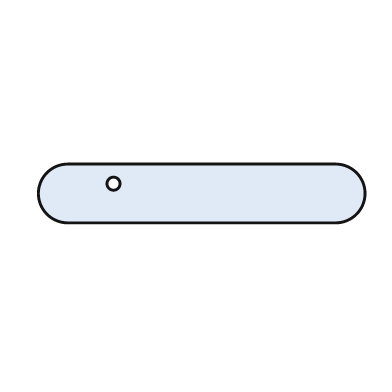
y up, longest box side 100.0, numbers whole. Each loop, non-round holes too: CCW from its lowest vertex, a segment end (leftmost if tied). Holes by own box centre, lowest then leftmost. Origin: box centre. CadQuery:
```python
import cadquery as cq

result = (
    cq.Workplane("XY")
    .moveTo(-41.0, -9.0)
    .lineTo(41.0, -9.0)
    .threePointArc((50.0, 0.0), (41.0, 9.0))
    .lineTo(-41.0, 9.0)
    .threePointArc((-50.0, 0.0), (-41.0, -9.0))
    .close()
    .moveTo(-27.0, 3.0)
    .circle(2.0)
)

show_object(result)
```